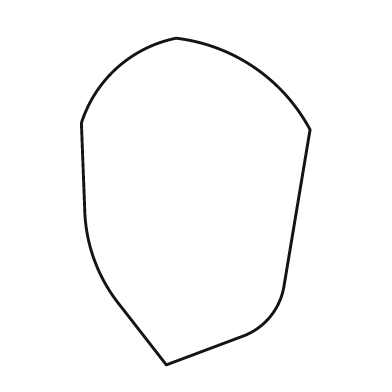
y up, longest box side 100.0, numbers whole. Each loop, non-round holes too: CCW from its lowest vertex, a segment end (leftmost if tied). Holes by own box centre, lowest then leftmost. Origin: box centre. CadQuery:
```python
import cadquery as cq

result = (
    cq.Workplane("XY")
    .moveTo(-9.0, -50.0)
    .lineTo(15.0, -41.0)
    .threePointArc((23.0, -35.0), (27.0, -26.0))
    .lineTo(35.0, 22.0)
    .threePointArc((18.0, 41.0), (-6.0, 50.0))
    .threePointArc((-24.0, 41.0), (-35.0, 24.0))
    .lineTo(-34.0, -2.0)
    .threePointArc((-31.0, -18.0), (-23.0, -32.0))
    .close()
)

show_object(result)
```